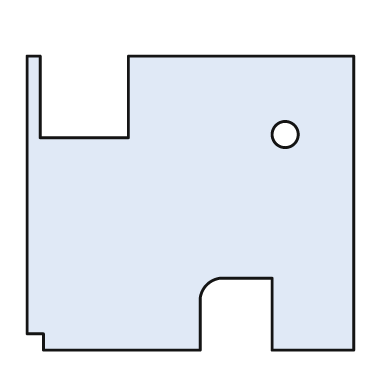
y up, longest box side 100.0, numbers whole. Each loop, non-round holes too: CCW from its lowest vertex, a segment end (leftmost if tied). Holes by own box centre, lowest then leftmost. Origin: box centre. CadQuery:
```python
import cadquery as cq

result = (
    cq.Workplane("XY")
    .moveTo(-45.0, -45.0)
    .lineTo(3.0, -45.0)
    .lineTo(3.0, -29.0)
    .threePointArc((5.0, -25.0), (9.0, -23.0))
    .lineTo(25.0, -23.0)
    .lineTo(25.0, -45.0)
    .lineTo(50.0, -45.0)
    .lineTo(50.0, 45.0)
    .lineTo(-19.0, 45.0)
    .lineTo(-19.0, 20.0)
    .lineTo(-46.0, 20.0)
    .lineTo(-46.0, 45.0)
    .lineTo(-50.0, 45.0)
    .lineTo(-50.0, -40.0)
    .lineTo(-45.0, -40.0)
    .close()
    .moveTo(29.0, 21.0)
    .circle(4.0)
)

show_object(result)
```